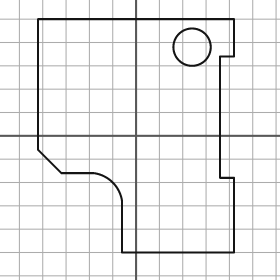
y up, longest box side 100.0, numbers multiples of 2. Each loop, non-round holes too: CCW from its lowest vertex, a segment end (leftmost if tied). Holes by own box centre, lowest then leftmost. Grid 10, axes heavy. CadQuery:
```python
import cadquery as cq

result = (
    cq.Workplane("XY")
    .moveTo(-6.0, -50.0)
    .lineTo(42.0, -50.0)
    .lineTo(42.0, -18.0)
    .lineTo(36.0, -18.0)
    .lineTo(36.0, 34.0)
    .lineTo(42.0, 34.0)
    .lineTo(42.0, 50.0)
    .lineTo(-42.0, 50.0)
    .lineTo(-42.0, -6.0)
    .lineTo(-32.0, -16.0)
    .lineTo(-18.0, -16.0)
    .threePointArc((-10.0, -20.0), (-6.0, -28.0))
    .close()
    .moveTo(24.0, 38.0)
    .circle(8.0)
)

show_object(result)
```